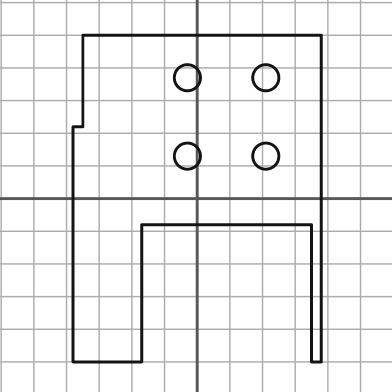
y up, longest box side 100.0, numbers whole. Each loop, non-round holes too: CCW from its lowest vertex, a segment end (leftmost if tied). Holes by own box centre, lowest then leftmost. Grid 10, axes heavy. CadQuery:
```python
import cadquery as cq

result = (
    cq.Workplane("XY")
    .moveTo(-38.0, -50.0)
    .lineTo(-17.0, -50.0)
    .lineTo(-17.0, -8.0)
    .lineTo(35.0, -8.0)
    .lineTo(35.0, -50.0)
    .lineTo(38.0, -50.0)
    .lineTo(38.0, 50.0)
    .lineTo(-35.0, 50.0)
    .lineTo(-35.0, 22.0)
    .lineTo(-38.0, 22.0)
    .close()
    .moveTo(-3.0, 13.0)
    .circle(4.0)
    .moveTo(21.0, 13.0)
    .circle(4.0)
    .moveTo(-3.0, 37.0)
    .circle(4.0)
    .moveTo(21.0, 37.0)
    .circle(4.0)
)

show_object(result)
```